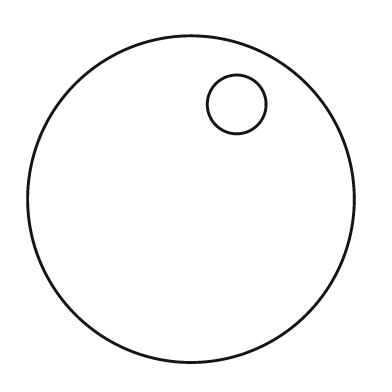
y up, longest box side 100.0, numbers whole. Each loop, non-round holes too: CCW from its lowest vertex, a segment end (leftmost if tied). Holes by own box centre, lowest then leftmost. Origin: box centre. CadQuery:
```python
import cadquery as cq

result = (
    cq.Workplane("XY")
    .moveTo(0.0, 0.0)
    .circle(50.0)
    .moveTo(14.0, 29.0)
    .circle(9.0)
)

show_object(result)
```